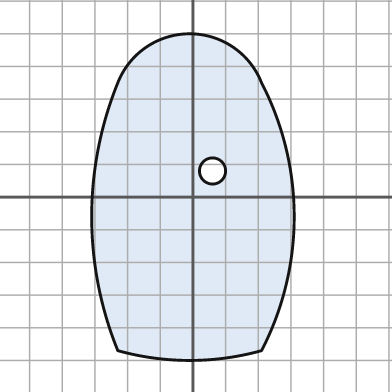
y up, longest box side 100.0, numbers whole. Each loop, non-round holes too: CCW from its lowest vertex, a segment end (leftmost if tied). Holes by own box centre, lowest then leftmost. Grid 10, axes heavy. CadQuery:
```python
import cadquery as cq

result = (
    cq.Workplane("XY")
    .moveTo(-23.0, -47.0)
    .threePointArc((-1.0, -50.0), (21.0, -47.0))
    .threePointArc((31.0, -6.0), (21.0, 35.0))
    .threePointArc((-1.0, 50.0), (-23.0, 35.0))
    .threePointArc((-31.0, -6.0), (-23.0, -47.0))
    .close()
    .moveTo(6.0, 8.0)
    .circle(4.0)
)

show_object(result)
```